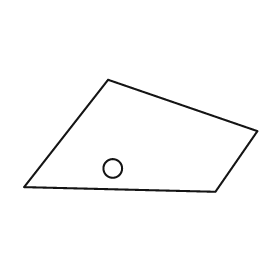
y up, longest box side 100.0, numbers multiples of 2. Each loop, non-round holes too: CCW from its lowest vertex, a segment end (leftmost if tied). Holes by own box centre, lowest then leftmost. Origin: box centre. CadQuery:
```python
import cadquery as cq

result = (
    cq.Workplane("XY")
    .moveTo(32.0, -24.0)
    .lineTo(50.0, 2.0)
    .lineTo(-14.0, 24.0)
    .lineTo(-50.0, -22.0)
    .close()
    .moveTo(-12.0, -14.0)
    .circle(4.0)
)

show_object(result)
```